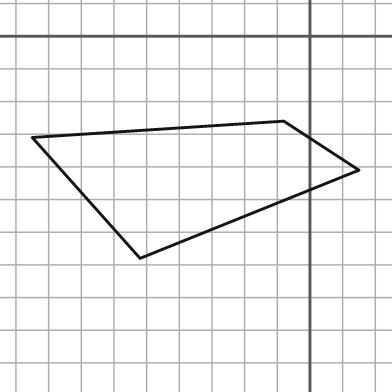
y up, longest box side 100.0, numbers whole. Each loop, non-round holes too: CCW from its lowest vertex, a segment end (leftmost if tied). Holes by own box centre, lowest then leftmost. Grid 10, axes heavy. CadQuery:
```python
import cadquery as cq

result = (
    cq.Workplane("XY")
    .moveTo(-52.0, -68.0)
    .lineTo(15.0, -41.0)
    .lineTo(-8.0, -26.0)
    .lineTo(-85.0, -31.0)
    .close()
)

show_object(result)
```